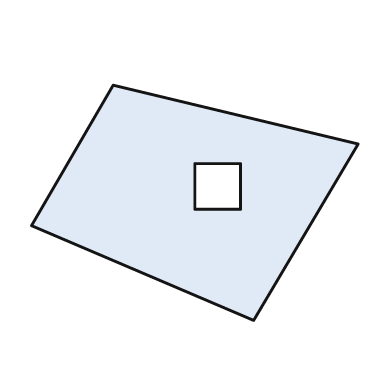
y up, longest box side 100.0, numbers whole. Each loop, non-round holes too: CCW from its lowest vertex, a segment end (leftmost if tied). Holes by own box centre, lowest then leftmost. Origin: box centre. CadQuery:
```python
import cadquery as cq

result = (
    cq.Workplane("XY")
    .moveTo(18.0, -36.0)
    .lineTo(50.0, 18.0)
    .lineTo(-25.0, 36.0)
    .lineTo(-50.0, -7.0)
    .close()
    .moveTo(0.0, -2.0)
    .lineTo(14.0, -2.0)
    .lineTo(14.0, 12.0)
    .lineTo(0.0, 12.0)
    .close()
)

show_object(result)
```